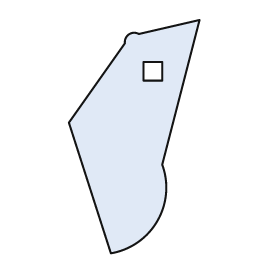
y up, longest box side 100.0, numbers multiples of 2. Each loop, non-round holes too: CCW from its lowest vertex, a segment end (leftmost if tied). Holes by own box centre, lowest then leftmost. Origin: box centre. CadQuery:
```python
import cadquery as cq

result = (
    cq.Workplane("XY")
    .moveTo(-10.0, -50.0)
    .threePointArc((10.0, -36.0), (12.0, -12.0))
    .lineTo(28.0, 50.0)
    .lineTo(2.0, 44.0)
    .threePointArc((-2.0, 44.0), (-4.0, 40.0))
    .lineTo(-28.0, 6.0)
    .close()
    .moveTo(4.0, 24.0)
    .lineTo(12.0, 24.0)
    .lineTo(12.0, 32.0)
    .lineTo(4.0, 32.0)
    .close()
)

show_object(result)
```